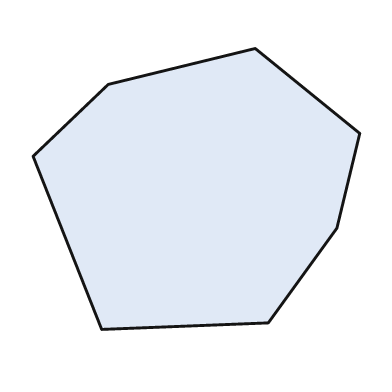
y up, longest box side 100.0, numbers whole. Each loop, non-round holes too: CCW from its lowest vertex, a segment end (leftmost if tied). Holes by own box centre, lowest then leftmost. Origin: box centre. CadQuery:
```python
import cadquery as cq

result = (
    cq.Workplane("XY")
    .moveTo(-29.0, -43.0)
    .lineTo(22.0, -41.0)
    .lineTo(43.0, -12.0)
    .lineTo(50.0, 17.0)
    .lineTo(18.0, 43.0)
    .lineTo(-27.0, 32.0)
    .lineTo(-50.0, 10.0)
    .close()
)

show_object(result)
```